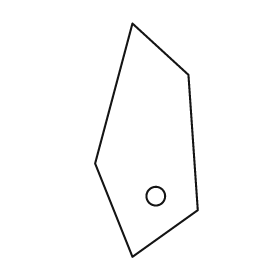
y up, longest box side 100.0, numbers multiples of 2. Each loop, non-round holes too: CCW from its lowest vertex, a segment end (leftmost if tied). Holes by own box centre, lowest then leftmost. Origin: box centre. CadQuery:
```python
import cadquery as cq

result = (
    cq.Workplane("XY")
    .moveTo(-6.0, -50.0)
    .lineTo(22.0, -30.0)
    .lineTo(18.0, 28.0)
    .lineTo(-6.0, 50.0)
    .lineTo(-22.0, -10.0)
    .close()
    .moveTo(4.0, -24.0)
    .circle(4.0)
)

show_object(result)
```